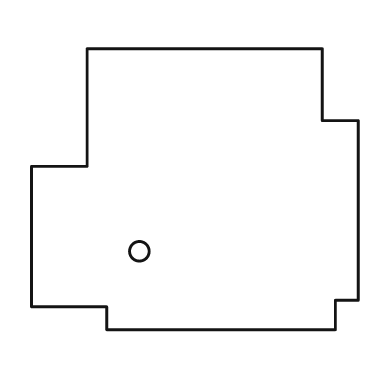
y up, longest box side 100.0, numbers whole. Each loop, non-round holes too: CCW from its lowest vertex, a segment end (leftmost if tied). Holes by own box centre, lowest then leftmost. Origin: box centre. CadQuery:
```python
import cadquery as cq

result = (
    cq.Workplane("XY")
    .moveTo(-27.0, -43.0)
    .lineTo(43.0, -43.0)
    .lineTo(43.0, -34.0)
    .lineTo(50.0, -34.0)
    .lineTo(50.0, 21.0)
    .lineTo(39.0, 21.0)
    .lineTo(39.0, 43.0)
    .lineTo(-33.0, 43.0)
    .lineTo(-33.0, 7.0)
    .lineTo(-50.0, 7.0)
    .lineTo(-50.0, -36.0)
    .lineTo(-27.0, -36.0)
    .close()
    .moveTo(-17.0, -19.0)
    .circle(3.0)
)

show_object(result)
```